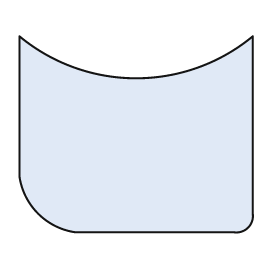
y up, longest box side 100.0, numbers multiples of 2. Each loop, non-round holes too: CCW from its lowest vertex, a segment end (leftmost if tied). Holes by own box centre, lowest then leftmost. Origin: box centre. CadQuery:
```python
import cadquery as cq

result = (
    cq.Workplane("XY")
    .moveTo(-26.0, -42.0)
    .lineTo(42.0, -42.0)
    .threePointArc((48.0, -40.0), (50.0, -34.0))
    .lineTo(50.0, 42.0)
    .threePointArc((0.0, 24.0), (-50.0, 42.0))
    .lineTo(-50.0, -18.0)
    .threePointArc((-42.0, -34.0), (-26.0, -42.0))
    .close()
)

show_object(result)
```